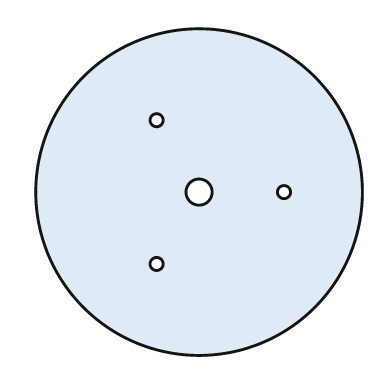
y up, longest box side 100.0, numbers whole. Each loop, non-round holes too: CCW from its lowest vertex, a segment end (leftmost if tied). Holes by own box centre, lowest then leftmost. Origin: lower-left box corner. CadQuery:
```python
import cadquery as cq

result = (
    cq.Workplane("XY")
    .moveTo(50.0, 50.0)
    .circle(50.0)
    .moveTo(37.0, 28.0)
    .circle(2.0)
    .moveTo(50.0, 50.0)
    .circle(4.0)
    .moveTo(76.0, 50.0)
    .circle(2.0)
    .moveTo(37.0, 72.0)
    .circle(2.0)
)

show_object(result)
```